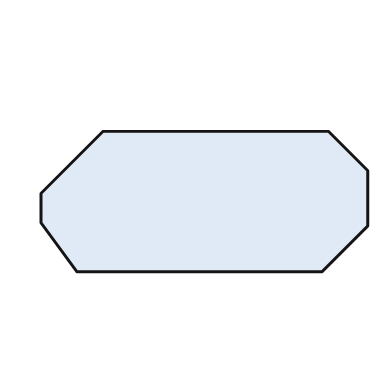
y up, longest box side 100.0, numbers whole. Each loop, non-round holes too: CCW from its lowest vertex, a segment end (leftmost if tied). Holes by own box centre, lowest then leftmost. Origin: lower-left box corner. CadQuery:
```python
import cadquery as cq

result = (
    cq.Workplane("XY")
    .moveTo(11.0, 0.0)
    .lineTo(86.0, 0.0)
    .lineTo(100.0, 14.0)
    .lineTo(100.0, 31.0)
    .lineTo(88.0, 43.0)
    .lineTo(19.0, 43.0)
    .lineTo(0.0, 24.0)
    .lineTo(0.0, 15.0)
    .close()
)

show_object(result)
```